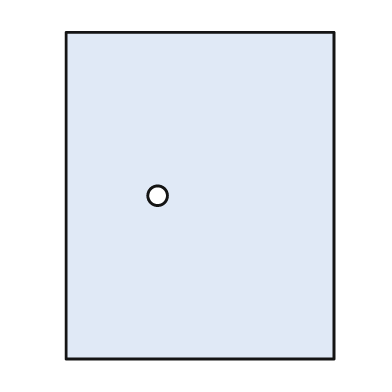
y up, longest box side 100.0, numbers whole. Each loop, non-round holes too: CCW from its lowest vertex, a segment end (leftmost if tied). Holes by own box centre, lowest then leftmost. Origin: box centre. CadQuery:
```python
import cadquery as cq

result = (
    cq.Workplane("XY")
    .moveTo(-41.0, -50.0)
    .lineTo(41.0, -50.0)
    .lineTo(41.0, 50.0)
    .lineTo(-41.0, 50.0)
    .close()
    .moveTo(-13.0, 0.0)
    .circle(3.0)
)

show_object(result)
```